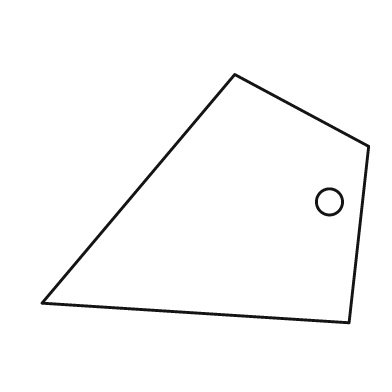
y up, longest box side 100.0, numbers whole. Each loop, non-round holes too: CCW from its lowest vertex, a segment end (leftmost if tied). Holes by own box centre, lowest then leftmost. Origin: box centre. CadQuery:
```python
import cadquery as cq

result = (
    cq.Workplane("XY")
    .moveTo(44.0, -38.0)
    .lineTo(50.0, 16.0)
    .lineTo(9.0, 38.0)
    .lineTo(-50.0, -32.0)
    .close()
    .moveTo(38.0, -1.0)
    .circle(4.0)
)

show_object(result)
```